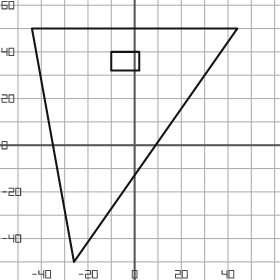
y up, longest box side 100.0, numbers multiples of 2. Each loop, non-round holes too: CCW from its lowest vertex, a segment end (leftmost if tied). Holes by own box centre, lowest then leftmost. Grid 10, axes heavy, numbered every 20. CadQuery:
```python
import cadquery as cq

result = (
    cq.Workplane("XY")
    .moveTo(-26.0, -50.0)
    .lineTo(44.0, 50.0)
    .lineTo(-44.0, 50.0)
    .close()
    .moveTo(-10.0, 32.0)
    .lineTo(2.0, 32.0)
    .lineTo(2.0, 40.0)
    .lineTo(-10.0, 40.0)
    .close()
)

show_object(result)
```